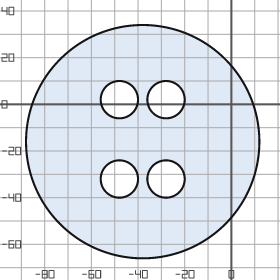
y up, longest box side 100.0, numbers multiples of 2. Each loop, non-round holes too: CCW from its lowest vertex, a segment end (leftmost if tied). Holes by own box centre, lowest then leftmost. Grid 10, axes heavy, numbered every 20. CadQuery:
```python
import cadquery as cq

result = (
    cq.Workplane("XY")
    .moveTo(-38.0, -16.0)
    .circle(50.0)
    .moveTo(-48.0, -32.0)
    .circle(8.0)
    .moveTo(-28.0, -32.0)
    .circle(8.0)
    .moveTo(-48.0, 2.0)
    .circle(8.0)
    .moveTo(-28.0, 2.0)
    .circle(8.0)
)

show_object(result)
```